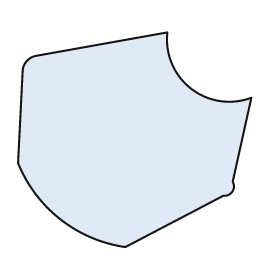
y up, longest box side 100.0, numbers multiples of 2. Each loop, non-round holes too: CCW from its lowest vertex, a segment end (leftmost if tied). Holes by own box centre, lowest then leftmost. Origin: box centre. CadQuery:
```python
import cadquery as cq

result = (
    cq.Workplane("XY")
    .moveTo(-4.0, -46.0)
    .lineTo(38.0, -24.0)
    .threePointArc((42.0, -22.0), (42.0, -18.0))
    .lineTo(50.0, 18.0)
    .threePointArc((24.0, 22.0), (14.0, 46.0))
    .lineTo(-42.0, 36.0)
    .threePointArc((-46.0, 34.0), (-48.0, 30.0))
    .lineTo(-50.0, -10.0)
    .threePointArc((-32.0, -34.0), (-4.0, -46.0))
    .close()
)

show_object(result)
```